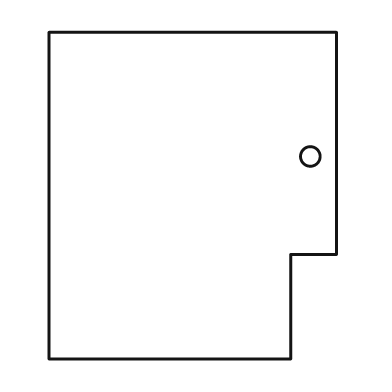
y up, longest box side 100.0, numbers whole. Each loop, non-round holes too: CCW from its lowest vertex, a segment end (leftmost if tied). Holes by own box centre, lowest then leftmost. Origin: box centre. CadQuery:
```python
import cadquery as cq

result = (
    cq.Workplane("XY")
    .moveTo(-44.0, -50.0)
    .lineTo(30.0, -50.0)
    .lineTo(30.0, -18.0)
    .lineTo(44.0, -18.0)
    .lineTo(44.0, 50.0)
    .lineTo(-44.0, 50.0)
    .close()
    .moveTo(36.0, 12.0)
    .circle(3.0)
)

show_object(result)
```